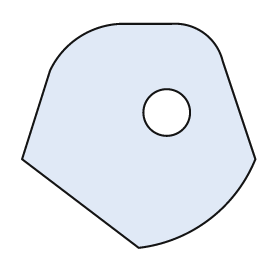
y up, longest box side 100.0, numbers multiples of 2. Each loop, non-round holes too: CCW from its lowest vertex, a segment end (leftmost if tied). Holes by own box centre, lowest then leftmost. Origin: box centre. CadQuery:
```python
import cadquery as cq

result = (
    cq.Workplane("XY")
    .moveTo(0.0, -48.0)
    .threePointArc((30.0, -36.0), (50.0, -10.0))
    .lineTo(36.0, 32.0)
    .threePointArc((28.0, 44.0), (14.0, 48.0))
    .lineTo(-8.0, 48.0)
    .threePointArc((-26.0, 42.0), (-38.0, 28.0))
    .lineTo(-50.0, -10.0)
    .close()
    .moveTo(12.0, 10.0)
    .circle(10.0)
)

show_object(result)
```